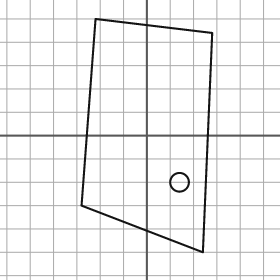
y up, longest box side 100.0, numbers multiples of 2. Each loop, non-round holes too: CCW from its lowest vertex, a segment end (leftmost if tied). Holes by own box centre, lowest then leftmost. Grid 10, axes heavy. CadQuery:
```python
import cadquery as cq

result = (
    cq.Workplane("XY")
    .moveTo(24.0, -50.0)
    .lineTo(28.0, 44.0)
    .lineTo(-22.0, 50.0)
    .lineTo(-28.0, -30.0)
    .close()
    .moveTo(14.0, -20.0)
    .circle(4.0)
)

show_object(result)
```